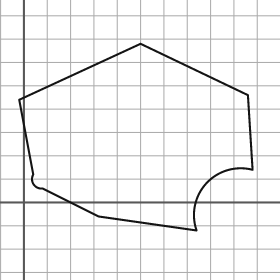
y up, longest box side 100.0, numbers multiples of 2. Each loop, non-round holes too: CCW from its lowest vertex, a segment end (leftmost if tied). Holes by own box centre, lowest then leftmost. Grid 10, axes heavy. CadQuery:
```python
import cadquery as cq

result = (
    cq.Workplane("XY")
    .moveTo(74.0, -12.0)
    .threePointArc((78.0, 8.0), (98.0, 14.0))
    .lineTo(96.0, 46.0)
    .lineTo(50.0, 68.0)
    .lineTo(-2.0, 44.0)
    .lineTo(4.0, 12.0)
    .threePointArc((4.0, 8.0), (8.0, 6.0))
    .lineTo(32.0, -6.0)
    .close()
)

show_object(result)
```